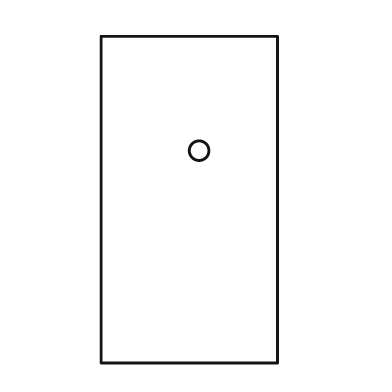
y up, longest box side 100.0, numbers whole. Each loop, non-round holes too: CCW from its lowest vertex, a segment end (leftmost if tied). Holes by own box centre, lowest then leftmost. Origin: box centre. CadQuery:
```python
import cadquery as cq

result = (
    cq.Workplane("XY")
    .moveTo(-27.0, -50.0)
    .lineTo(27.0, -50.0)
    .lineTo(27.0, 50.0)
    .lineTo(-27.0, 50.0)
    .close()
    .moveTo(3.0, 15.0)
    .circle(3.0)
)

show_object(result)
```